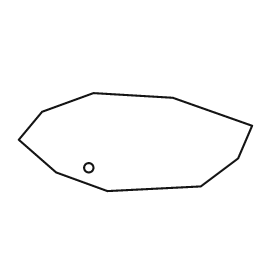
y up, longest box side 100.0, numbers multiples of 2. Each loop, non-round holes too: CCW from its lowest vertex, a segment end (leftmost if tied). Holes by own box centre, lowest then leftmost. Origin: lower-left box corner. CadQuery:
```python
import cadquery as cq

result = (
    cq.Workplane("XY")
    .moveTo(38.0, 0.0)
    .lineTo(78.0, 2.0)
    .lineTo(94.0, 14.0)
    .lineTo(100.0, 28.0)
    .lineTo(66.0, 40.0)
    .lineTo(32.0, 42.0)
    .lineTo(10.0, 34.0)
    .lineTo(0.0, 22.0)
    .lineTo(16.0, 8.0)
    .close()
    .moveTo(30.0, 10.0)
    .circle(2.0)
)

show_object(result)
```